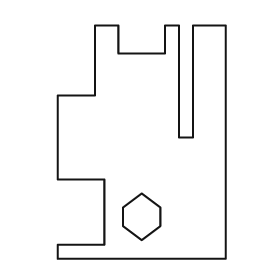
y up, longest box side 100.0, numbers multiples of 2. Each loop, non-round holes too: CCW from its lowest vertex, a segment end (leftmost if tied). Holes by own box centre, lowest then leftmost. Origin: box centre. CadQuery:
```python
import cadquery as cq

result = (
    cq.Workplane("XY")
    .moveTo(-36.0, -50.0)
    .lineTo(36.0, -50.0)
    .lineTo(36.0, 50.0)
    .lineTo(22.0, 50.0)
    .lineTo(22.0, 2.0)
    .lineTo(16.0, 2.0)
    .lineTo(16.0, 50.0)
    .lineTo(10.0, 50.0)
    .lineTo(10.0, 38.0)
    .lineTo(-10.0, 38.0)
    .lineTo(-10.0, 50.0)
    .lineTo(-20.0, 50.0)
    .lineTo(-20.0, 20.0)
    .lineTo(-36.0, 20.0)
    .lineTo(-36.0, -16.0)
    .lineTo(-16.0, -16.0)
    .lineTo(-16.0, -44.0)
    .lineTo(-36.0, -44.0)
    .close()
    .moveTo(0.0, -42.0)
    .lineTo(8.0, -36.0)
    .lineTo(8.0, -28.0)
    .lineTo(0.0, -22.0)
    .lineTo(-8.0, -28.0)
    .lineTo(-8.0, -36.0)
    .close()
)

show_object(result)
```